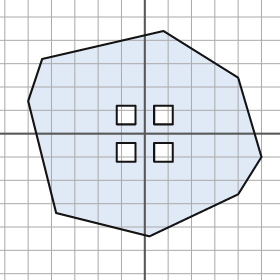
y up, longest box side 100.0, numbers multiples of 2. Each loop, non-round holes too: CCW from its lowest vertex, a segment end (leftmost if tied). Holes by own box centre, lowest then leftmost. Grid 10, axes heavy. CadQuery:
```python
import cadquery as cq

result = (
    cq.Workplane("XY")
    .moveTo(2.0, -44.0)
    .lineTo(40.0, -26.0)
    .lineTo(50.0, -10.0)
    .lineTo(40.0, 24.0)
    .lineTo(8.0, 44.0)
    .lineTo(-44.0, 32.0)
    .lineTo(-50.0, 14.0)
    .lineTo(-38.0, -34.0)
    .close()
    .moveTo(-12.0, -12.0)
    .lineTo(-4.0, -12.0)
    .lineTo(-4.0, -4.0)
    .lineTo(-12.0, -4.0)
    .close()
    .moveTo(4.0, -12.0)
    .lineTo(12.0, -12.0)
    .lineTo(12.0, -4.0)
    .lineTo(4.0, -4.0)
    .close()
    .moveTo(-12.0, 4.0)
    .lineTo(-4.0, 4.0)
    .lineTo(-4.0, 12.0)
    .lineTo(-12.0, 12.0)
    .close()
    .moveTo(4.0, 4.0)
    .lineTo(12.0, 4.0)
    .lineTo(12.0, 12.0)
    .lineTo(4.0, 12.0)
    .close()
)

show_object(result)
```